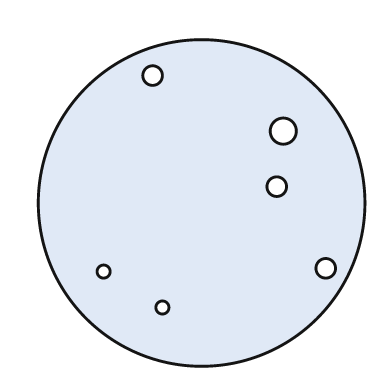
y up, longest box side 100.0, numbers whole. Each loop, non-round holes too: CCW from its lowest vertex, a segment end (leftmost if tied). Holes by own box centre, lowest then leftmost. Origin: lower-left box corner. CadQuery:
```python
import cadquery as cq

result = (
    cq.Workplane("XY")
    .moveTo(50.0, 50.0)
    .circle(50.0)
    .moveTo(38.0, 18.0)
    .circle(2.0)
    .moveTo(20.0, 29.0)
    .circle(2.0)
    .moveTo(88.0, 30.0)
    .circle(3.0)
    .moveTo(73.0, 55.0)
    .circle(3.0)
    .moveTo(75.0, 72.0)
    .circle(4.0)
    .moveTo(35.0, 89.0)
    .circle(3.0)
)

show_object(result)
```